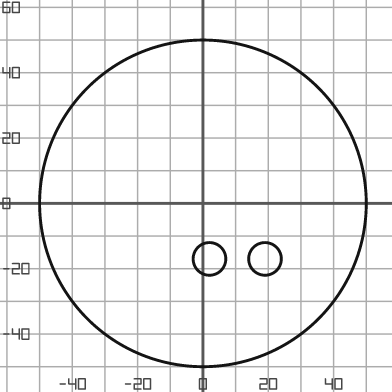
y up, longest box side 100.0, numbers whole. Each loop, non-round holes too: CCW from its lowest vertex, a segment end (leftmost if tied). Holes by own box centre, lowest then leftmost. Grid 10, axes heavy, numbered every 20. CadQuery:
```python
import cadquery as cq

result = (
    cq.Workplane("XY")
    .moveTo(0.0, 0.0)
    .circle(50.0)
    .moveTo(2.0, -17.0)
    .circle(5.0)
    .moveTo(19.0, -17.0)
    .circle(5.0)
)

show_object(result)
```